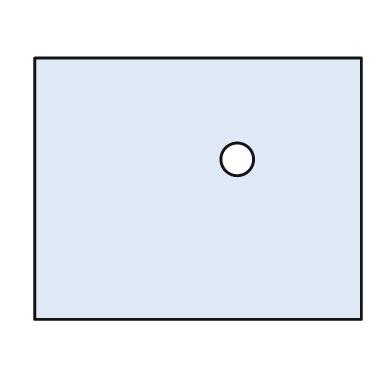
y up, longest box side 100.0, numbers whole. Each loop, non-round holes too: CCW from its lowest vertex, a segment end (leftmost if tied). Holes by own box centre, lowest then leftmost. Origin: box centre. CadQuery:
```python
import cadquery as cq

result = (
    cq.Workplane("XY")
    .moveTo(-50.0, -40.0)
    .lineTo(50.0, -40.0)
    .lineTo(50.0, 40.0)
    .lineTo(-50.0, 40.0)
    .close()
    .moveTo(12.0, 9.0)
    .circle(5.0)
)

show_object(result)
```